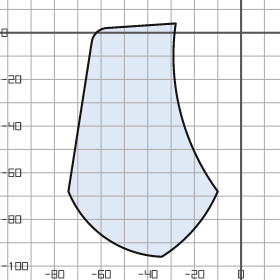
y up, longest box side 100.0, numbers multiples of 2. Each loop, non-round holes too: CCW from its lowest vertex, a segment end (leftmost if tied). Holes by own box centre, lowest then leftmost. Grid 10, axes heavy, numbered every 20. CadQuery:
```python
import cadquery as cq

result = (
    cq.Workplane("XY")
    .moveTo(-34.0, -96.0)
    .threePointArc((-20.0, -84.0), (-10.0, -68.0))
    .threePointArc((-26.0, -34.0), (-28.0, 4.0))
    .lineTo(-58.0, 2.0)
    .threePointArc((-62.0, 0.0), (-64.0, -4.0))
    .lineTo(-74.0, -68.0)
    .threePointArc((-58.0, -88.0), (-34.0, -96.0))
    .close()
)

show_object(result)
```